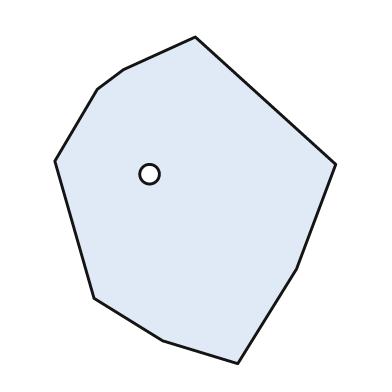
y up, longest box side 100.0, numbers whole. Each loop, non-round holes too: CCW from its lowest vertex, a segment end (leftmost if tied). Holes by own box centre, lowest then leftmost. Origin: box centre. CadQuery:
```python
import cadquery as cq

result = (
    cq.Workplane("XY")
    .moveTo(13.0, -50.0)
    .lineTo(31.0, -21.0)
    .lineTo(43.0, 11.0)
    .lineTo(0.0, 50.0)
    .lineTo(-22.0, 40.0)
    .lineTo(-30.0, 34.0)
    .lineTo(-43.0, 12.0)
    .lineTo(-31.0, -30.0)
    .lineTo(-10.0, -43.0)
    .close()
    .moveTo(-14.0, 8.0)
    .circle(3.0)
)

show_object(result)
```